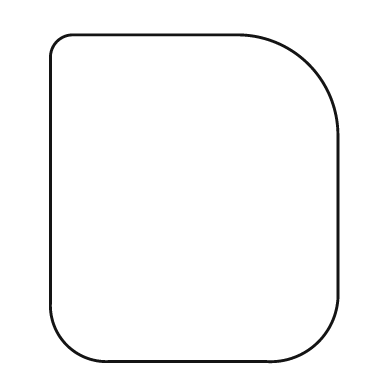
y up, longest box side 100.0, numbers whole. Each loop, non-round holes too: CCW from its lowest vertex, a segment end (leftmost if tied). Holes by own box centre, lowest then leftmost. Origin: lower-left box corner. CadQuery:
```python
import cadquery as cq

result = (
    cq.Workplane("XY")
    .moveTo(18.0, 0.0)
    .lineTo(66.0, 0.0)
    .threePointArc((82.0, 6.0), (88.0, 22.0))
    .lineTo(88.0, 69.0)
    .threePointArc((79.0, 91.0), (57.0, 100.0))
    .lineTo(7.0, 100.0)
    .threePointArc((2.0, 98.0), (0.0, 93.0))
    .lineTo(0.0, 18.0)
    .threePointArc((5.0, 5.0), (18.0, 0.0))
    .close()
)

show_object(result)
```